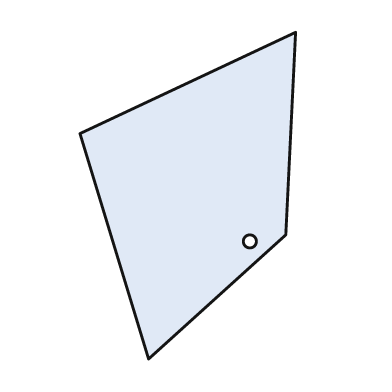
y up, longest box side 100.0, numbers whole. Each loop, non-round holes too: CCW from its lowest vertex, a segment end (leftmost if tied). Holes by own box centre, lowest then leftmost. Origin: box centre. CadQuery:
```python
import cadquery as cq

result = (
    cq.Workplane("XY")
    .moveTo(-12.0, -50.0)
    .lineTo(30.0, -12.0)
    .lineTo(33.0, 50.0)
    .lineTo(-33.0, 19.0)
    .close()
    .moveTo(19.0, -14.0)
    .circle(2.0)
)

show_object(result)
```